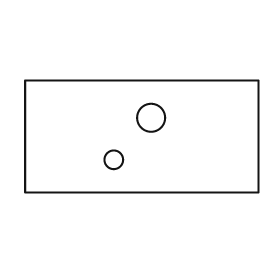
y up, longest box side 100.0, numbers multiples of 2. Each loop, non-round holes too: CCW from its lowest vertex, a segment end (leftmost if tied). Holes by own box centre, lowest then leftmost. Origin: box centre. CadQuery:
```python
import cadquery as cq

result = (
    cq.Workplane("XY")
    .moveTo(-50.0, -24.0)
    .lineTo(50.0, -24.0)
    .lineTo(50.0, 24.0)
    .lineTo(-50.0, 24.0)
    .close()
    .moveTo(-12.0, -10.0)
    .circle(4.0)
    .moveTo(4.0, 8.0)
    .circle(6.0)
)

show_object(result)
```